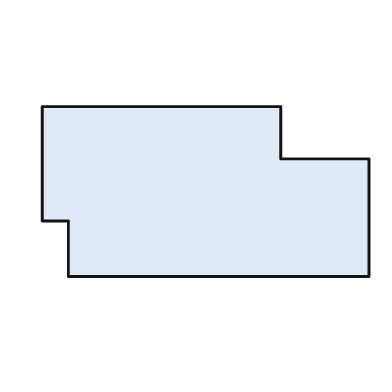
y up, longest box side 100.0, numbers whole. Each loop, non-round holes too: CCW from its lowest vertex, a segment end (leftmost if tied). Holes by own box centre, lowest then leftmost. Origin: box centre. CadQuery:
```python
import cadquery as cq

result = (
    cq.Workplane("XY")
    .moveTo(-42.0, -26.0)
    .lineTo(50.0, -26.0)
    .lineTo(50.0, 10.0)
    .lineTo(23.0, 10.0)
    .lineTo(23.0, 26.0)
    .lineTo(-50.0, 26.0)
    .lineTo(-50.0, -9.0)
    .lineTo(-42.0, -9.0)
    .close()
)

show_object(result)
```